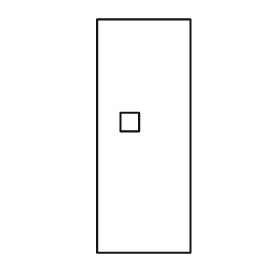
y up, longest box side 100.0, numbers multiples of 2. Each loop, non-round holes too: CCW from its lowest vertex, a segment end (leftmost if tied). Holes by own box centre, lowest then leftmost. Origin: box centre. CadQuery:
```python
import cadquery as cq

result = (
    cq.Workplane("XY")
    .moveTo(-20.0, -50.0)
    .lineTo(20.0, -50.0)
    .lineTo(20.0, 50.0)
    .lineTo(-20.0, 50.0)
    .close()
    .moveTo(-10.0, 2.0)
    .lineTo(-2.0, 2.0)
    .lineTo(-2.0, 10.0)
    .lineTo(-10.0, 10.0)
    .close()
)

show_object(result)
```